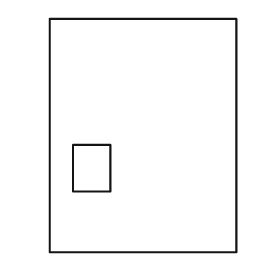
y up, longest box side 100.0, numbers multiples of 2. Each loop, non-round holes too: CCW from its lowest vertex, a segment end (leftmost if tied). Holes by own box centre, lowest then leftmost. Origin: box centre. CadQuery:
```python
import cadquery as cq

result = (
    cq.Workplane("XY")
    .moveTo(-40.0, -50.0)
    .lineTo(40.0, -50.0)
    .lineTo(40.0, 50.0)
    .lineTo(-40.0, 50.0)
    .close()
    .moveTo(-30.0, -24.0)
    .lineTo(-14.0, -24.0)
    .lineTo(-14.0, -4.0)
    .lineTo(-30.0, -4.0)
    .close()
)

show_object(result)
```